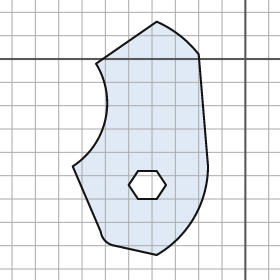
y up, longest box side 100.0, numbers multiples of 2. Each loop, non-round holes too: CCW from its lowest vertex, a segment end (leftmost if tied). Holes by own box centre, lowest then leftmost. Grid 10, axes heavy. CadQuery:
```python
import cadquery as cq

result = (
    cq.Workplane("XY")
    .moveTo(-38.0, -84.0)
    .threePointArc((-22.0, -68.0), (-16.0, -46.0))
    .lineTo(-20.0, 2.0)
    .threePointArc((-28.0, 10.0), (-38.0, 16.0))
    .lineTo(-64.0, -2.0)
    .threePointArc((-60.0, -26.0), (-74.0, -46.0))
    .lineTo(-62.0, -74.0)
    .threePointArc((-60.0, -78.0), (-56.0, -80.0))
    .close()
    .moveTo(-46.0, -60.0)
    .lineTo(-38.0, -60.0)
    .lineTo(-34.0, -54.0)
    .lineTo(-38.0, -48.0)
    .lineTo(-46.0, -48.0)
    .lineTo(-50.0, -54.0)
    .close()
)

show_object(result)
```